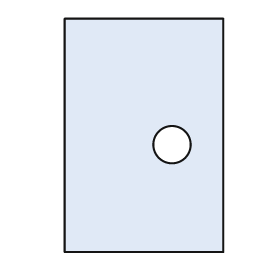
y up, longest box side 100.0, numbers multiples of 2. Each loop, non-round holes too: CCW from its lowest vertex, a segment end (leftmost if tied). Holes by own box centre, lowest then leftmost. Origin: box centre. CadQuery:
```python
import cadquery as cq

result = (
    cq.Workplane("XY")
    .moveTo(-34.0, -50.0)
    .lineTo(34.0, -50.0)
    .lineTo(34.0, 50.0)
    .lineTo(-34.0, 50.0)
    .close()
    .moveTo(12.0, -4.0)
    .circle(8.0)
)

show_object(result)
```